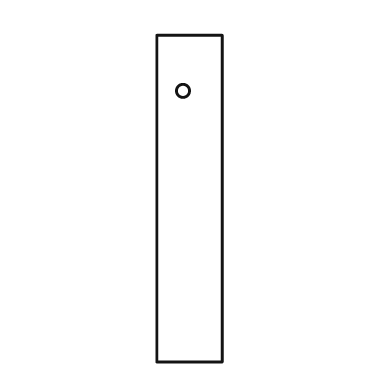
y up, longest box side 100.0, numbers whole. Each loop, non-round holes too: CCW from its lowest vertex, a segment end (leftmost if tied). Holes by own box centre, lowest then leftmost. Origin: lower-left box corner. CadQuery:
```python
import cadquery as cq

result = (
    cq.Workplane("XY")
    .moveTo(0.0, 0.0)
    .lineTo(20.0, 0.0)
    .lineTo(20.0, 100.0)
    .lineTo(0.0, 100.0)
    .close()
    .moveTo(8.0, 83.0)
    .circle(2.0)
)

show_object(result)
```